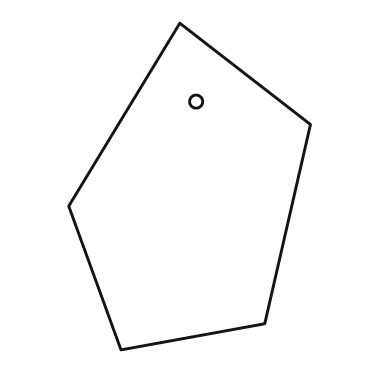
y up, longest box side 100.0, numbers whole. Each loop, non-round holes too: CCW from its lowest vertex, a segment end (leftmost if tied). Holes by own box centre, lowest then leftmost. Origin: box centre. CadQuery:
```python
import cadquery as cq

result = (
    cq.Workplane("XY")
    .moveTo(-21.0, -50.0)
    .lineTo(23.0, -42.0)
    .lineTo(37.0, 19.0)
    .lineTo(-3.0, 50.0)
    .lineTo(-37.0, -6.0)
    .close()
    .moveTo(2.0, 26.0)
    .circle(2.0)
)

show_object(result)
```